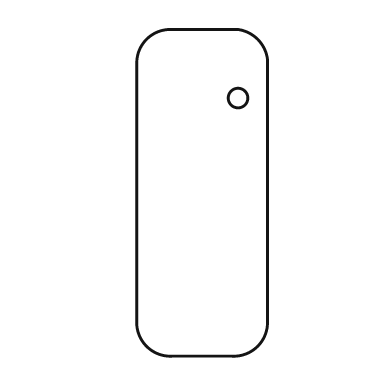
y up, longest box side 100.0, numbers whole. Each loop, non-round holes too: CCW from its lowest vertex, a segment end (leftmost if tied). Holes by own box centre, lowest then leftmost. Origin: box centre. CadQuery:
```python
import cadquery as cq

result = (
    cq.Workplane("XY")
    .moveTo(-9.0, -50.0)
    .lineTo(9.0, -50.0)
    .threePointArc((17.0, -47.0), (20.0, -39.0))
    .lineTo(20.0, 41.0)
    .threePointArc((17.0, 47.0), (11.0, 50.0))
    .lineTo(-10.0, 50.0)
    .threePointArc((-17.0, 47.0), (-20.0, 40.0))
    .lineTo(-20.0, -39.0)
    .threePointArc((-17.0, -47.0), (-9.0, -50.0))
    .close()
    .moveTo(11.0, 29.0)
    .circle(3.0)
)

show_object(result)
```